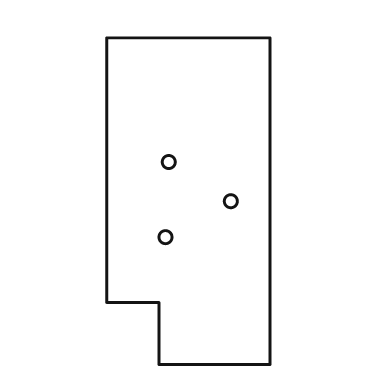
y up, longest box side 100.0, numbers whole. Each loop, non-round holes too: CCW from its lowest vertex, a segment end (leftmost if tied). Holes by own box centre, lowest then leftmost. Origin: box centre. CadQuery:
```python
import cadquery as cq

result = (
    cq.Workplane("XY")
    .moveTo(-9.0, -50.0)
    .lineTo(25.0, -50.0)
    .lineTo(25.0, 50.0)
    .lineTo(-25.0, 50.0)
    .lineTo(-25.0, -31.0)
    .lineTo(-9.0, -31.0)
    .close()
    .moveTo(-7.0, -11.0)
    .circle(2.0)
    .moveTo(13.0, 0.0)
    .circle(2.0)
    .moveTo(-6.0, 12.0)
    .circle(2.0)
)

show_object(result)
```